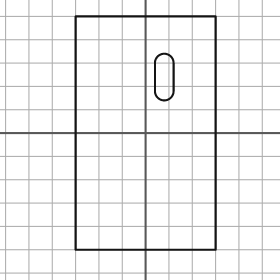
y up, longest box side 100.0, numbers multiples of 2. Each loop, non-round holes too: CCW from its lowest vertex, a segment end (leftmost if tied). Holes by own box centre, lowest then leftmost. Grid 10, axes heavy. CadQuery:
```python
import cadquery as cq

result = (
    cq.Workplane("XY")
    .moveTo(-30.0, -50.0)
    .lineTo(30.0, -50.0)
    .lineTo(30.0, 50.0)
    .lineTo(-30.0, 50.0)
    .close()
    .moveTo(4.0, 18.0)
    .threePointArc((8.0, 14.0), (12.0, 18.0))
    .lineTo(12.0, 30.0)
    .threePointArc((8.0, 34.0), (4.0, 30.0))
    .close()
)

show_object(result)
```